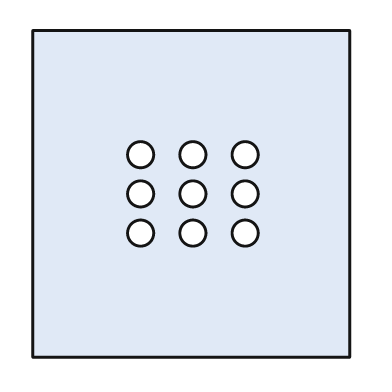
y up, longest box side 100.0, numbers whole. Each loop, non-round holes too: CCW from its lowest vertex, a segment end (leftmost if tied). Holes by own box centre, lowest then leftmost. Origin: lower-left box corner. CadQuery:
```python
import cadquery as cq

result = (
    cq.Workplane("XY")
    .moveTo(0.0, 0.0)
    .lineTo(97.0, 0.0)
    .lineTo(97.0, 100.0)
    .lineTo(0.0, 100.0)
    .close()
    .moveTo(33.0, 38.0)
    .circle(4.0)
    .moveTo(49.0, 38.0)
    .circle(4.0)
    .moveTo(65.0, 38.0)
    .circle(4.0)
    .moveTo(33.0, 50.0)
    .circle(4.0)
    .moveTo(49.0, 50.0)
    .circle(4.0)
    .moveTo(65.0, 50.0)
    .circle(4.0)
    .moveTo(33.0, 62.0)
    .circle(4.0)
    .moveTo(49.0, 62.0)
    .circle(4.0)
    .moveTo(65.0, 62.0)
    .circle(4.0)
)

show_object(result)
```